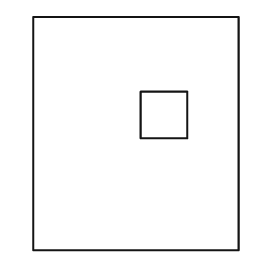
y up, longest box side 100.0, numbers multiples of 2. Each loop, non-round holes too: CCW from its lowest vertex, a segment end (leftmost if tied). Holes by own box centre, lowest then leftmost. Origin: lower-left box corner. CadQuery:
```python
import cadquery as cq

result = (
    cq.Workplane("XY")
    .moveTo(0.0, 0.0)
    .lineTo(88.0, 0.0)
    .lineTo(88.0, 100.0)
    .lineTo(0.0, 100.0)
    .close()
    .moveTo(46.0, 48.0)
    .lineTo(66.0, 48.0)
    .lineTo(66.0, 68.0)
    .lineTo(46.0, 68.0)
    .close()
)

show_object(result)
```